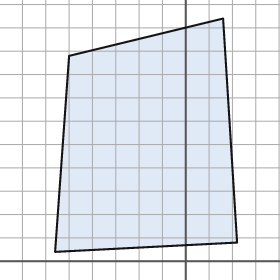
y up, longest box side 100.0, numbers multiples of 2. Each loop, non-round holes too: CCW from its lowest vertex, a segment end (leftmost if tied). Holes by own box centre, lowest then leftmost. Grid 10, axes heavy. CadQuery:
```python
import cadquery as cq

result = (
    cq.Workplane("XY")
    .moveTo(-56.0, 4.0)
    .lineTo(22.0, 8.0)
    .lineTo(16.0, 104.0)
    .lineTo(-50.0, 88.0)
    .close()
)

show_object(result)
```